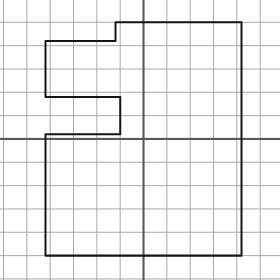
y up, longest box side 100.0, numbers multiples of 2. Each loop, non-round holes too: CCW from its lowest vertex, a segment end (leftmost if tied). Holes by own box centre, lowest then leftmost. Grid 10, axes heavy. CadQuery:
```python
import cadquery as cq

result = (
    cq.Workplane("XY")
    .moveTo(-42.0, -50.0)
    .lineTo(42.0, -50.0)
    .lineTo(42.0, 50.0)
    .lineTo(-12.0, 50.0)
    .lineTo(-12.0, 42.0)
    .lineTo(-42.0, 42.0)
    .lineTo(-42.0, 18.0)
    .lineTo(-10.0, 18.0)
    .lineTo(-10.0, 2.0)
    .lineTo(-42.0, 2.0)
    .close()
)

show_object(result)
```